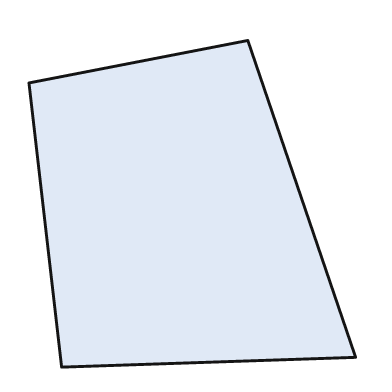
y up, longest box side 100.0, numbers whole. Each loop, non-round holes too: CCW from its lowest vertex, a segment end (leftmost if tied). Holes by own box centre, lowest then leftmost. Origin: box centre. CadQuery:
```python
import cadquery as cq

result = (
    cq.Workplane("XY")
    .moveTo(-40.0, -50.0)
    .lineTo(50.0, -47.0)
    .lineTo(17.0, 50.0)
    .lineTo(-50.0, 37.0)
    .close()
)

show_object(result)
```